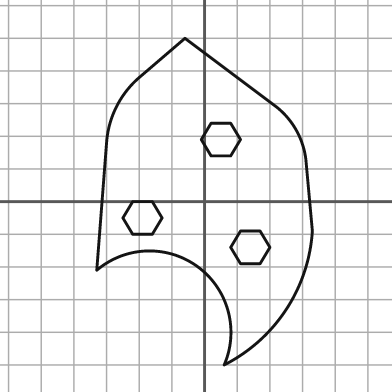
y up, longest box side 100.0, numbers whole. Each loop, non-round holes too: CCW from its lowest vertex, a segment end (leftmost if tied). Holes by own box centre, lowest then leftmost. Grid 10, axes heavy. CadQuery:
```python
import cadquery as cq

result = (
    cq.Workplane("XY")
    .moveTo(6.0, -50.0)
    .threePointArc((25.0, -33.0), (33.0, -9.0))
    .lineTo(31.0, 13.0)
    .threePointArc((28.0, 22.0), (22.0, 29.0))
    .lineTo(-6.0, 50.0)
    .lineTo(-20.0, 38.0)
    .threePointArc((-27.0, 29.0), (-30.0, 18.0))
    .lineTo(-33.0, -21.0)
    .threePointArc((-2.0, -20.0), (6.0, -50.0))
    .close()
    .moveTo(11.0, -19.0)
    .lineTo(17.0, -19.0)
    .lineTo(20.0, -14.0)
    .lineTo(17.0, -9.0)
    .lineTo(11.0, -9.0)
    .lineTo(8.0, -14.0)
    .close()
    .moveTo(-22.0, -10.0)
    .lineTo(-16.0, -10.0)
    .lineTo(-13.0, -5.0)
    .lineTo(-16.0, 0.0)
    .lineTo(-22.0, 0.0)
    .lineTo(-25.0, -5.0)
    .close()
    .moveTo(2.0, 14.0)
    .lineTo(8.0, 14.0)
    .lineTo(11.0, 19.0)
    .lineTo(8.0, 24.0)
    .lineTo(2.0, 24.0)
    .lineTo(-1.0, 19.0)
    .close()
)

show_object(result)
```